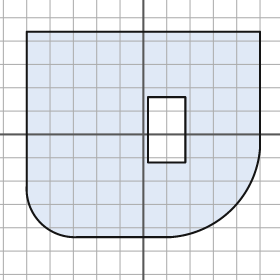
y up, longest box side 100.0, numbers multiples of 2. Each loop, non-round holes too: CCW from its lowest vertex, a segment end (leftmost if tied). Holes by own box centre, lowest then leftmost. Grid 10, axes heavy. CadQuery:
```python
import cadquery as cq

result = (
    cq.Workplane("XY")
    .moveTo(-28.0, -44.0)
    .lineTo(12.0, -44.0)
    .threePointArc((38.0, -32.0), (50.0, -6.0))
    .lineTo(50.0, 44.0)
    .lineTo(-50.0, 44.0)
    .lineTo(-50.0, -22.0)
    .threePointArc((-44.0, -38.0), (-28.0, -44.0))
    .close()
    .moveTo(2.0, -12.0)
    .lineTo(18.0, -12.0)
    .lineTo(18.0, 16.0)
    .lineTo(2.0, 16.0)
    .close()
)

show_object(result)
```